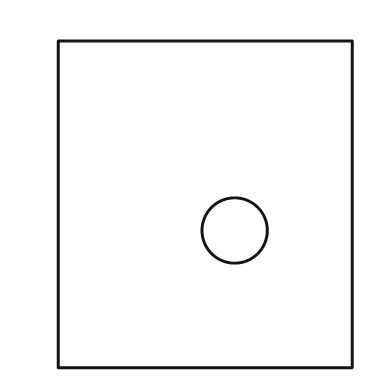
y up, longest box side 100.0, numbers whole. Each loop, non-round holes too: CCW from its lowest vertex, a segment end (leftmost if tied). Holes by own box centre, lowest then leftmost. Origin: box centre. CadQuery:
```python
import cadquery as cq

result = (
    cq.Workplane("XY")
    .moveTo(-45.0, -50.0)
    .lineTo(45.0, -50.0)
    .lineTo(45.0, 50.0)
    .lineTo(-45.0, 50.0)
    .close()
    .moveTo(9.0, -8.0)
    .circle(10.0)
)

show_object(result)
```